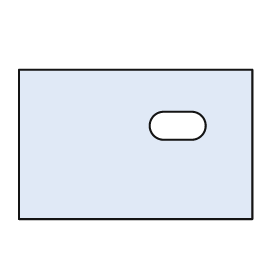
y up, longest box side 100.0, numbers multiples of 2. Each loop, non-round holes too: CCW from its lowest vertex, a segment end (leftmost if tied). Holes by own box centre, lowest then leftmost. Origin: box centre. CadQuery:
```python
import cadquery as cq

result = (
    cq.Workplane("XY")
    .moveTo(-50.0, -32.0)
    .lineTo(50.0, -32.0)
    .lineTo(50.0, 32.0)
    .lineTo(-50.0, 32.0)
    .close()
    .moveTo(12.0, 2.0)
    .lineTo(24.0, 2.0)
    .threePointArc((30.0, 8.0), (24.0, 14.0))
    .lineTo(12.0, 14.0)
    .threePointArc((6.0, 8.0), (12.0, 2.0))
    .close()
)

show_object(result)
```